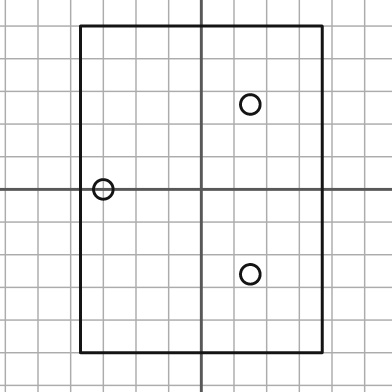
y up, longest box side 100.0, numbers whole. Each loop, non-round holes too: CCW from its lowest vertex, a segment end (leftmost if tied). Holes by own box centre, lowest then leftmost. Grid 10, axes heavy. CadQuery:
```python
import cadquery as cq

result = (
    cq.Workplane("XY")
    .moveTo(-37.0, -50.0)
    .lineTo(37.0, -50.0)
    .lineTo(37.0, 50.0)
    .lineTo(-37.0, 50.0)
    .close()
    .moveTo(15.0, -26.0)
    .circle(3.0)
    .moveTo(-30.0, 0.0)
    .circle(3.0)
    .moveTo(15.0, 26.0)
    .circle(3.0)
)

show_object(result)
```